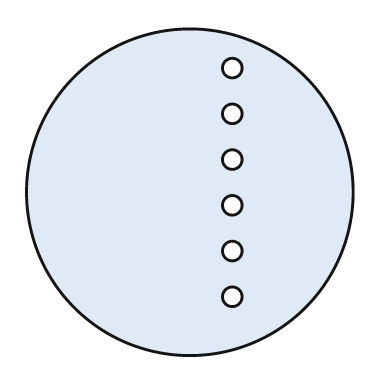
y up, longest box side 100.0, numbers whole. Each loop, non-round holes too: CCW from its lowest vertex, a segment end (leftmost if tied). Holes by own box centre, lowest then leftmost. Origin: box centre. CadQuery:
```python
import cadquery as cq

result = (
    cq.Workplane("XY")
    .moveTo(0.0, 0.0)
    .circle(50.0)
    .moveTo(13.0, -32.0)
    .circle(3.0)
    .moveTo(13.0, -18.0)
    .circle(3.0)
    .moveTo(13.0, -4.0)
    .circle(3.0)
    .moveTo(13.0, 10.0)
    .circle(3.0)
    .moveTo(13.0, 24.0)
    .circle(3.0)
    .moveTo(13.0, 38.0)
    .circle(3.0)
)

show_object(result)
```